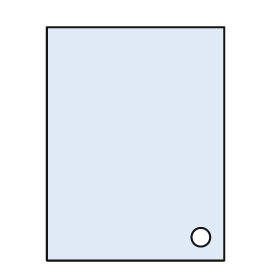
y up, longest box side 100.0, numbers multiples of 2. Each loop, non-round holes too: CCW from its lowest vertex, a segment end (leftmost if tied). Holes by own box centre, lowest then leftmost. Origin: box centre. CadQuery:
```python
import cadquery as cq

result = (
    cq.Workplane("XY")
    .moveTo(-38.0, -50.0)
    .lineTo(38.0, -50.0)
    .lineTo(38.0, 50.0)
    .lineTo(-38.0, 50.0)
    .close()
    .moveTo(28.0, -40.0)
    .circle(4.0)
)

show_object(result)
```